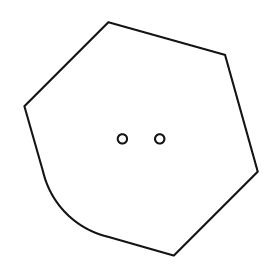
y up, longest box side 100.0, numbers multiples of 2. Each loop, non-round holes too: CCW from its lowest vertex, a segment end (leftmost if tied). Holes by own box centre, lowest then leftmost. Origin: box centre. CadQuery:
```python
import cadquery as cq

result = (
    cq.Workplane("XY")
    .moveTo(14.0, -50.0)
    .lineTo(50.0, -14.0)
    .lineTo(36.0, 36.0)
    .lineTo(-14.0, 50.0)
    .lineTo(-50.0, 14.0)
    .lineTo(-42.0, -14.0)
    .threePointArc((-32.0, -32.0), (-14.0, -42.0))
    .close()
    .moveTo(-8.0, 0.0)
    .circle(2.0)
    .moveTo(8.0, 0.0)
    .circle(2.0)
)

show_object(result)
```